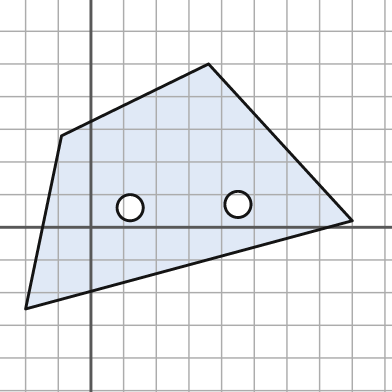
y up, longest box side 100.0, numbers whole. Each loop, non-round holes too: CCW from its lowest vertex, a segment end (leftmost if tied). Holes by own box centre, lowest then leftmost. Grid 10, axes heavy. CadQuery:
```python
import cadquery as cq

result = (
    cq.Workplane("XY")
    .moveTo(-20.0, -25.0)
    .lineTo(80.0, 2.0)
    .lineTo(36.0, 50.0)
    .lineTo(-9.0, 28.0)
    .close()
    .moveTo(12.0, 6.0)
    .circle(4.0)
    .moveTo(45.0, 7.0)
    .circle(4.0)
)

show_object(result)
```